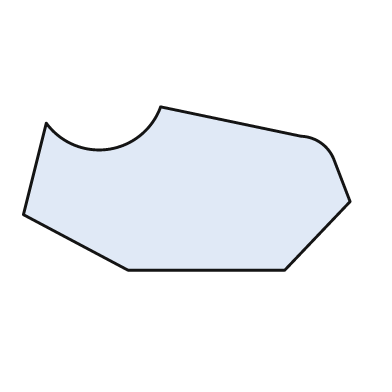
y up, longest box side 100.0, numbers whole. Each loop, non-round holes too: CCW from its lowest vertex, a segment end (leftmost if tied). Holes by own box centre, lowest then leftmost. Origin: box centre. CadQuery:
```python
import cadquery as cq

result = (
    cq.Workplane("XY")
    .moveTo(-18.0, -25.0)
    .lineTo(30.0, -25.0)
    .lineTo(50.0, -4.0)
    .lineTo(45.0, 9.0)
    .threePointArc((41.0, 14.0), (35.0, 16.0))
    .lineTo(-8.0, 25.0)
    .threePointArc((-24.0, 12.0), (-43.0, 20.0))
    .lineTo(-50.0, -8.0)
    .close()
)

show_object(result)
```